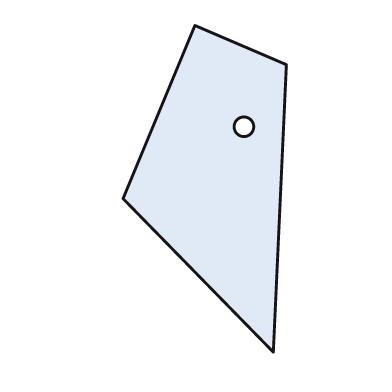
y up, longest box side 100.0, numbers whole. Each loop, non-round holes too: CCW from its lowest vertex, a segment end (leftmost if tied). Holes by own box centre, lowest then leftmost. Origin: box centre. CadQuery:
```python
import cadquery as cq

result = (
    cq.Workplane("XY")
    .moveTo(21.0, -50.0)
    .lineTo(25.0, 38.0)
    .lineTo(-3.0, 50.0)
    .lineTo(-25.0, -3.0)
    .close()
    .moveTo(12.0, 19.0)
    .circle(3.0)
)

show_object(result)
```